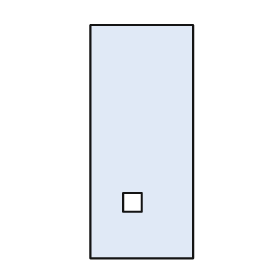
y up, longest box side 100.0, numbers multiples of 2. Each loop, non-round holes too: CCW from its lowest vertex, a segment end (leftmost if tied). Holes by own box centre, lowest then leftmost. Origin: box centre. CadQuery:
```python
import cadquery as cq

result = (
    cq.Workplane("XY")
    .moveTo(-22.0, -50.0)
    .lineTo(22.0, -50.0)
    .lineTo(22.0, 50.0)
    .lineTo(-22.0, 50.0)
    .close()
    .moveTo(-8.0, -30.0)
    .lineTo(0.0, -30.0)
    .lineTo(0.0, -22.0)
    .lineTo(-8.0, -22.0)
    .close()
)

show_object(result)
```